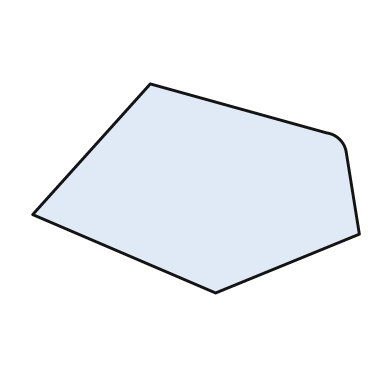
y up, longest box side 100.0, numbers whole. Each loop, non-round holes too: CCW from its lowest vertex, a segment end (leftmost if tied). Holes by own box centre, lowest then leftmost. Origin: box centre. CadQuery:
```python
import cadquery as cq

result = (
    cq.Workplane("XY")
    .moveTo(6.0, -32.0)
    .lineTo(50.0, -14.0)
    .lineTo(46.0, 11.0)
    .threePointArc((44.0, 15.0), (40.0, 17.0))
    .lineTo(-14.0, 32.0)
    .lineTo(-50.0, -8.0)
    .close()
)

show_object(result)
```